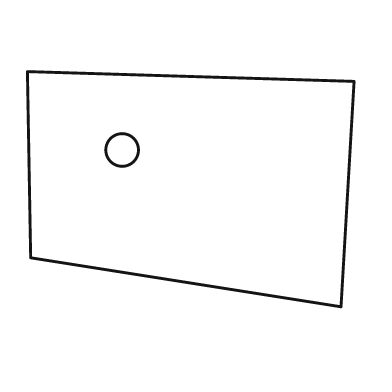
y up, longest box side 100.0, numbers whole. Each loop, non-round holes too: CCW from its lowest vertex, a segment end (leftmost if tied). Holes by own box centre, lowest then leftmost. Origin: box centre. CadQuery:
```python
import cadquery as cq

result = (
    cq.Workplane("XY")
    .moveTo(46.0, -36.0)
    .lineTo(50.0, 33.0)
    .lineTo(-50.0, 36.0)
    .lineTo(-49.0, -21.0)
    .close()
    .moveTo(-21.0, 12.0)
    .circle(5.0)
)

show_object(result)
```